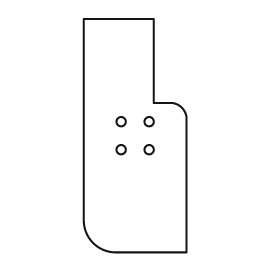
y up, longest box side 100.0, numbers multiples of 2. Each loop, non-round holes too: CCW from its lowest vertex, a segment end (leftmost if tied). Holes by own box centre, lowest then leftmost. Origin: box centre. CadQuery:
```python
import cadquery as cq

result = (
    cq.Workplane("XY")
    .moveTo(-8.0, -50.0)
    .lineTo(22.0, -50.0)
    .lineTo(22.0, 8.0)
    .threePointArc((20.0, 12.0), (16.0, 14.0))
    .lineTo(8.0, 14.0)
    .lineTo(8.0, 50.0)
    .lineTo(-22.0, 50.0)
    .lineTo(-22.0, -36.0)
    .threePointArc((-18.0, -46.0), (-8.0, -50.0))
    .close()
    .moveTo(-6.0, -6.0)
    .circle(2.0)
    .moveTo(6.0, -6.0)
    .circle(2.0)
    .moveTo(-6.0, 6.0)
    .circle(2.0)
    .moveTo(6.0, 6.0)
    .circle(2.0)
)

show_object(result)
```